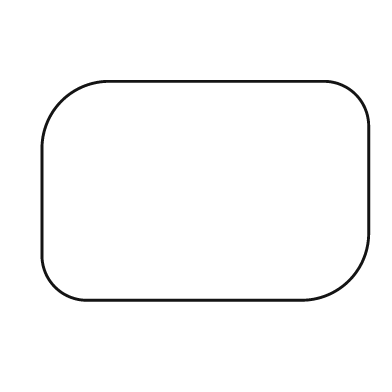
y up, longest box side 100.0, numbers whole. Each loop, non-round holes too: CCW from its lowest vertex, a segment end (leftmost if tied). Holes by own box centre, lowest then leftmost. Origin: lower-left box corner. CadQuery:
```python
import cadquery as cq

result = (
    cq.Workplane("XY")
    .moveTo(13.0, 0.0)
    .lineTo(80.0, 0.0)
    .threePointArc((94.0, 6.0), (100.0, 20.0))
    .lineTo(100.0, 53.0)
    .threePointArc((96.0, 63.0), (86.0, 67.0))
    .lineTo(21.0, 67.0)
    .threePointArc((6.0, 61.0), (0.0, 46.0))
    .lineTo(0.0, 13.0)
    .threePointArc((4.0, 4.0), (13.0, 0.0))
    .close()
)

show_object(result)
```